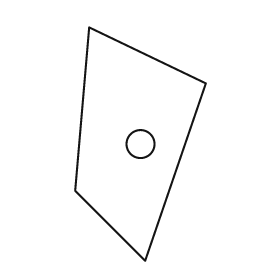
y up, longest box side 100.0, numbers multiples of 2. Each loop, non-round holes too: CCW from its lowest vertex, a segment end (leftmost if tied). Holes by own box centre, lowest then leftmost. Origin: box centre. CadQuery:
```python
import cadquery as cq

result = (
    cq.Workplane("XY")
    .moveTo(2.0, -50.0)
    .lineTo(28.0, 26.0)
    .lineTo(-22.0, 50.0)
    .lineTo(-28.0, -20.0)
    .close()
    .moveTo(0.0, 0.0)
    .circle(6.0)
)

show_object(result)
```